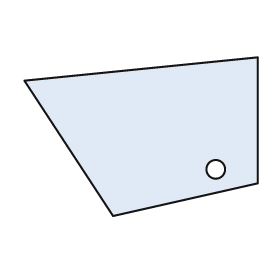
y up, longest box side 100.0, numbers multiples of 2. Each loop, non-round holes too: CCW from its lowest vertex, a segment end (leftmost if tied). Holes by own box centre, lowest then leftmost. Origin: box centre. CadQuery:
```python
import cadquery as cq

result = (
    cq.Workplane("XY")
    .moveTo(-12.0, -34.0)
    .lineTo(50.0, -20.0)
    .lineTo(50.0, 34.0)
    .lineTo(-50.0, 24.0)
    .close()
    .moveTo(32.0, -14.0)
    .circle(4.0)
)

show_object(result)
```